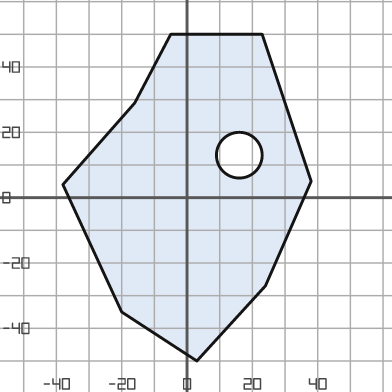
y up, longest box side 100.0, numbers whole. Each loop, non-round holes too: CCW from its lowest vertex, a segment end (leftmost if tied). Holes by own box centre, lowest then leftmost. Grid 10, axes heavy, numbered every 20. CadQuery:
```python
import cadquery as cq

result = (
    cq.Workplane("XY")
    .moveTo(3.0, -50.0)
    .lineTo(24.0, -27.0)
    .lineTo(38.0, 5.0)
    .lineTo(23.0, 50.0)
    .lineTo(-5.0, 50.0)
    .lineTo(-16.0, 29.0)
    .lineTo(-38.0, 4.0)
    .lineTo(-20.0, -35.0)
    .close()
    .moveTo(16.0, 13.0)
    .circle(7.0)
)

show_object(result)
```